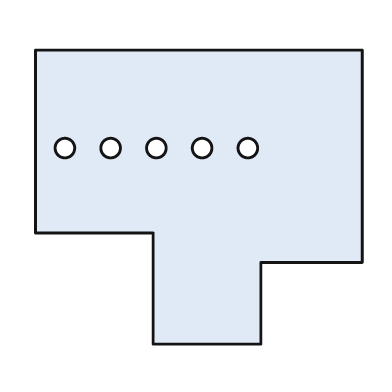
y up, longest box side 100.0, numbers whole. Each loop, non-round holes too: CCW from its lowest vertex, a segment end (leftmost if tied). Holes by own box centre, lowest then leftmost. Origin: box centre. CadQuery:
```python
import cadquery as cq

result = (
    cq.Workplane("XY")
    .moveTo(-14.0, -45.0)
    .lineTo(19.0, -45.0)
    .lineTo(19.0, -20.0)
    .lineTo(50.0, -20.0)
    .lineTo(50.0, 45.0)
    .lineTo(-50.0, 45.0)
    .lineTo(-50.0, -11.0)
    .lineTo(-14.0, -11.0)
    .close()
    .moveTo(-41.0, 15.0)
    .circle(3.0)
    .moveTo(-27.0, 15.0)
    .circle(3.0)
    .moveTo(-13.0, 15.0)
    .circle(3.0)
    .moveTo(1.0, 15.0)
    .circle(3.0)
    .moveTo(15.0, 15.0)
    .circle(3.0)
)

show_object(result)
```